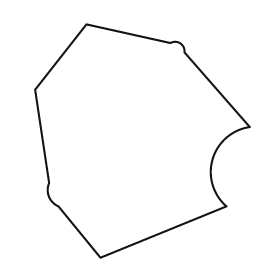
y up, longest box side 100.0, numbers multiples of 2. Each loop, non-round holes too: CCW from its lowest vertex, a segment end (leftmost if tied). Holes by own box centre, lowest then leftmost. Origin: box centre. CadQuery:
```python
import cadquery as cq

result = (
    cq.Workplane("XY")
    .moveTo(-18.0, -50.0)
    .lineTo(36.0, -28.0)
    .threePointArc((30.0, -8.0), (46.0, 6.0))
    .lineTo(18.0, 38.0)
    .threePointArc((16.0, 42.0), (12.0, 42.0))
    .lineTo(-24.0, 50.0)
    .lineTo(-46.0, 22.0)
    .lineTo(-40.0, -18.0)
    .threePointArc((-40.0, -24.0), (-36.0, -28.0))
    .close()
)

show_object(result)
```